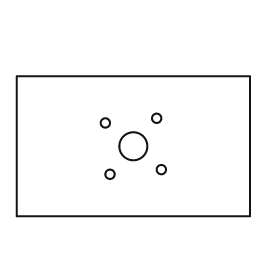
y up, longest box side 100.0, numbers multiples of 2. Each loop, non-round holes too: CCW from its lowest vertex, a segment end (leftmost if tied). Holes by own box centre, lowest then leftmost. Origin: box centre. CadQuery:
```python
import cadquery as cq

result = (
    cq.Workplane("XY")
    .moveTo(-50.0, -30.0)
    .lineTo(50.0, -30.0)
    .lineTo(50.0, 30.0)
    .lineTo(-50.0, 30.0)
    .close()
    .moveTo(-10.0, -12.0)
    .circle(2.0)
    .moveTo(12.0, -10.0)
    .circle(2.0)
    .moveTo(0.0, 0.0)
    .circle(6.0)
    .moveTo(-12.0, 10.0)
    .circle(2.0)
    .moveTo(10.0, 12.0)
    .circle(2.0)
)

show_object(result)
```